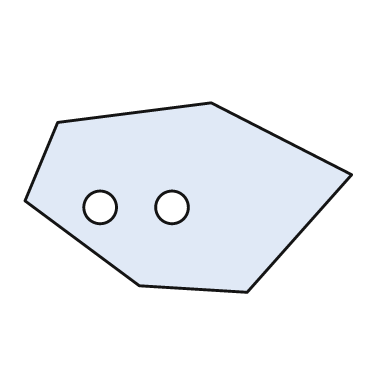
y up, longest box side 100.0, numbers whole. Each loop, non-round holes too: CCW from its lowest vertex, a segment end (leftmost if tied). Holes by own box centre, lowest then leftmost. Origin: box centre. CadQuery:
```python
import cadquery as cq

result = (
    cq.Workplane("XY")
    .moveTo(18.0, -29.0)
    .lineTo(50.0, 7.0)
    .lineTo(7.0, 29.0)
    .lineTo(-40.0, 23.0)
    .lineTo(-50.0, -1.0)
    .lineTo(-15.0, -27.0)
    .close()
    .moveTo(-27.0, -3.0)
    .circle(5.0)
    .moveTo(-5.0, -3.0)
    .circle(5.0)
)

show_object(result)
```